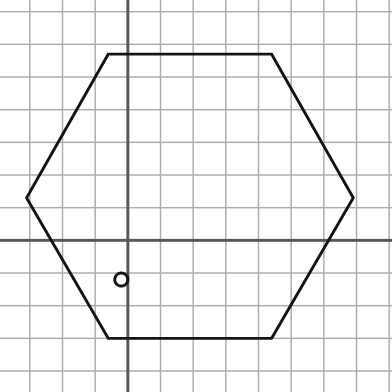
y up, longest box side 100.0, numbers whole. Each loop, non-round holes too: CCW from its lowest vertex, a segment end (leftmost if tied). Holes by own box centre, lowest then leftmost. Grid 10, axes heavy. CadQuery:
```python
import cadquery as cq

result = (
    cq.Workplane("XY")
    .moveTo(-6.0, -30.0)
    .lineTo(44.0, -30.0)
    .lineTo(69.0, 13.0)
    .lineTo(44.0, 57.0)
    .lineTo(-6.0, 57.0)
    .lineTo(-31.0, 13.0)
    .close()
    .moveTo(-2.0, -12.0)
    .circle(2.0)
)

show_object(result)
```